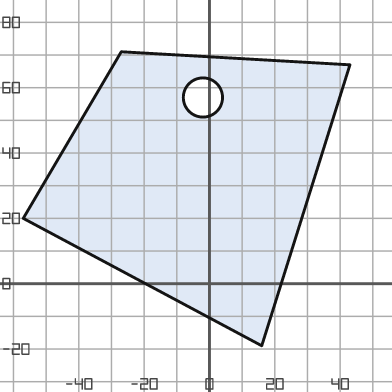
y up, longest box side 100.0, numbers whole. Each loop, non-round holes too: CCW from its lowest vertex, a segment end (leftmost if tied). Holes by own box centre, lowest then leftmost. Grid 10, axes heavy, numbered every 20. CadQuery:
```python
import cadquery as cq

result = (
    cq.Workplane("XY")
    .moveTo(16.0, -19.0)
    .lineTo(43.0, 67.0)
    .lineTo(-27.0, 71.0)
    .lineTo(-57.0, 20.0)
    .close()
    .moveTo(-2.0, 57.0)
    .circle(6.0)
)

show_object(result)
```